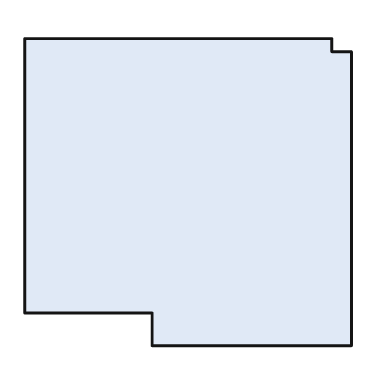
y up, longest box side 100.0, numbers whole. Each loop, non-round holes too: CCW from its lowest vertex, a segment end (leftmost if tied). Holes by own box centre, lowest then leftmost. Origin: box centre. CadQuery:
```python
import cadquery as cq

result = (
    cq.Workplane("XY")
    .moveTo(-11.0, -47.0)
    .lineTo(50.0, -47.0)
    .lineTo(50.0, 43.0)
    .lineTo(44.0, 43.0)
    .lineTo(44.0, 47.0)
    .lineTo(-50.0, 47.0)
    .lineTo(-50.0, -37.0)
    .lineTo(-11.0, -37.0)
    .close()
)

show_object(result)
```